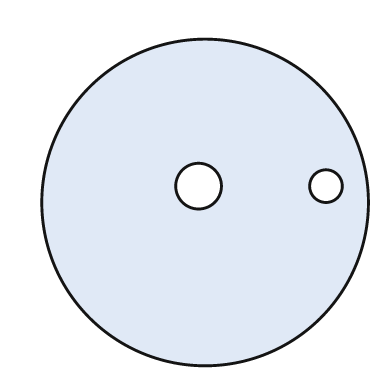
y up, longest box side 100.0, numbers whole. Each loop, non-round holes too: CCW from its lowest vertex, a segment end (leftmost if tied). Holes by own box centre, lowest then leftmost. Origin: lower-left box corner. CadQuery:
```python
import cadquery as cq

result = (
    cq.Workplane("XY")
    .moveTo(50.0, 50.0)
    .circle(50.0)
    .moveTo(48.0, 55.0)
    .circle(7.0)
    .moveTo(87.0, 55.0)
    .circle(5.0)
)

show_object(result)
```